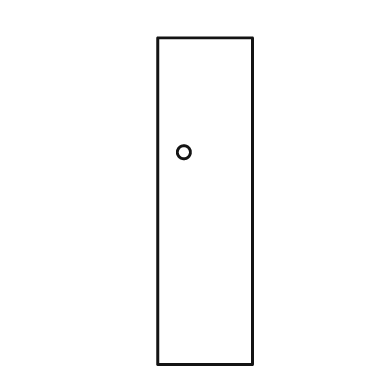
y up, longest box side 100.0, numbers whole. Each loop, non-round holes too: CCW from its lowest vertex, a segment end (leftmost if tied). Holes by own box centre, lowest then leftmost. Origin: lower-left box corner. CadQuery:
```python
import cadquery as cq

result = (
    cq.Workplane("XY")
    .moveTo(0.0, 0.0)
    .lineTo(29.0, 0.0)
    .lineTo(29.0, 100.0)
    .lineTo(0.0, 100.0)
    .close()
    .moveTo(8.0, 65.0)
    .circle(2.0)
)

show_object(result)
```